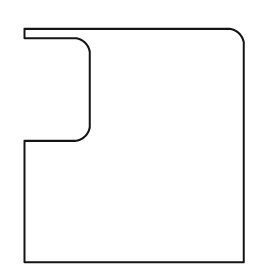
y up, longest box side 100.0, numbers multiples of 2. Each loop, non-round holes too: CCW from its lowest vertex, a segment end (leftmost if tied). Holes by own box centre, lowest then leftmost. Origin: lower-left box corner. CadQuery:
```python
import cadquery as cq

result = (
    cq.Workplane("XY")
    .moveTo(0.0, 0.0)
    .lineTo(94.0, 0.0)
    .lineTo(94.0, 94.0)
    .threePointArc((92.0, 98.0), (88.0, 100.0))
    .lineTo(0.0, 100.0)
    .lineTo(0.0, 96.0)
    .lineTo(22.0, 96.0)
    .threePointArc((26.0, 94.0), (28.0, 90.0))
    .lineTo(28.0, 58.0)
    .threePointArc((26.0, 54.0), (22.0, 52.0))
    .lineTo(0.0, 52.0)
    .close()
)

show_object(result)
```